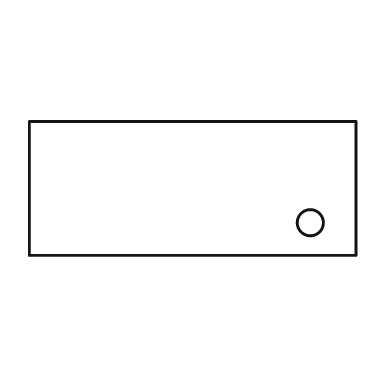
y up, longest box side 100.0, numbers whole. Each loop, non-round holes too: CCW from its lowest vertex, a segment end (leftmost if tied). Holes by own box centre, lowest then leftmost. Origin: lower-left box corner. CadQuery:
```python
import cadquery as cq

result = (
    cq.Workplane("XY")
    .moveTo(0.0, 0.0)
    .lineTo(100.0, 0.0)
    .lineTo(100.0, 41.0)
    .lineTo(0.0, 41.0)
    .close()
    .moveTo(86.0, 10.0)
    .circle(4.0)
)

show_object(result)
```